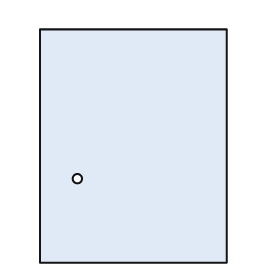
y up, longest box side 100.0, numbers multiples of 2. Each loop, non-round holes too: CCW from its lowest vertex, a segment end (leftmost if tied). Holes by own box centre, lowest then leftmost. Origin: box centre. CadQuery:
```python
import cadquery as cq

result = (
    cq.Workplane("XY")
    .moveTo(-40.0, -50.0)
    .lineTo(40.0, -50.0)
    .lineTo(40.0, 50.0)
    .lineTo(-40.0, 50.0)
    .close()
    .moveTo(-24.0, -14.0)
    .circle(2.0)
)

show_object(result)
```